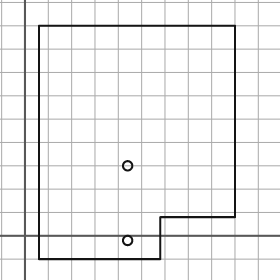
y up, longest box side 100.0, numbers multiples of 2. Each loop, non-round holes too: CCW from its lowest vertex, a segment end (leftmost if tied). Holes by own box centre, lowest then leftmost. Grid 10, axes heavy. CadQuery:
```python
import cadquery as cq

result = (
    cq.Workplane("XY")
    .moveTo(6.0, -10.0)
    .lineTo(58.0, -10.0)
    .lineTo(58.0, 8.0)
    .lineTo(90.0, 8.0)
    .lineTo(90.0, 90.0)
    .lineTo(6.0, 90.0)
    .close()
    .moveTo(44.0, -2.0)
    .circle(2.0)
    .moveTo(44.0, 30.0)
    .circle(2.0)
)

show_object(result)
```